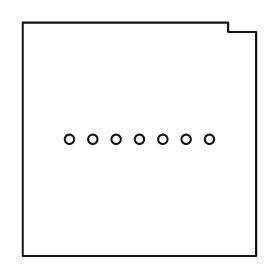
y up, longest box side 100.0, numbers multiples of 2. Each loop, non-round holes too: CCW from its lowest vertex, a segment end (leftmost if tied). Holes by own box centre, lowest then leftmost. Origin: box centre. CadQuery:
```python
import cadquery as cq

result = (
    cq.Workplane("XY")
    .moveTo(-50.0, -50.0)
    .lineTo(50.0, -50.0)
    .lineTo(50.0, 46.0)
    .lineTo(38.0, 46.0)
    .lineTo(38.0, 50.0)
    .lineTo(-50.0, 50.0)
    .close()
    .moveTo(-30.0, 0.0)
    .circle(2.0)
    .moveTo(-20.0, 0.0)
    .circle(2.0)
    .moveTo(-10.0, 0.0)
    .circle(2.0)
    .moveTo(0.0, 0.0)
    .circle(2.0)
    .moveTo(10.0, 0.0)
    .circle(2.0)
    .moveTo(20.0, 0.0)
    .circle(2.0)
    .moveTo(30.0, 0.0)
    .circle(2.0)
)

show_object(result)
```